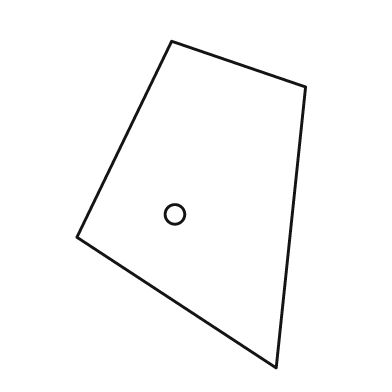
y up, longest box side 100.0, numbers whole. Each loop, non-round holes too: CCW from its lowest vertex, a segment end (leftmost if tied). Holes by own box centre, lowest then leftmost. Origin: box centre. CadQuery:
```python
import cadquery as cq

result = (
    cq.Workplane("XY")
    .moveTo(26.0, -50.0)
    .lineTo(35.0, 36.0)
    .lineTo(-6.0, 50.0)
    .lineTo(-35.0, -10.0)
    .close()
    .moveTo(-5.0, -3.0)
    .circle(3.0)
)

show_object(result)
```